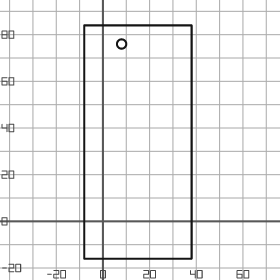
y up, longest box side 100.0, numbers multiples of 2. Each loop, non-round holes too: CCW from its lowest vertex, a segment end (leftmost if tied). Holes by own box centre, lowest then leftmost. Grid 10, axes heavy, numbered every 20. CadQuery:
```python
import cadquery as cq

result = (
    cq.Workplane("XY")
    .moveTo(-8.0, -16.0)
    .lineTo(38.0, -16.0)
    .lineTo(38.0, 84.0)
    .lineTo(-8.0, 84.0)
    .close()
    .moveTo(8.0, 76.0)
    .circle(2.0)
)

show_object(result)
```